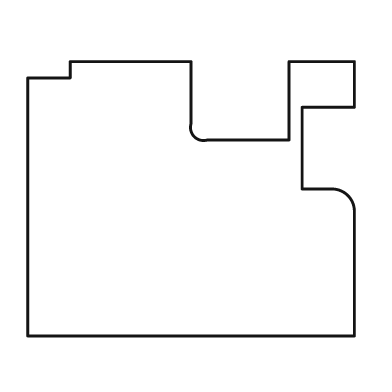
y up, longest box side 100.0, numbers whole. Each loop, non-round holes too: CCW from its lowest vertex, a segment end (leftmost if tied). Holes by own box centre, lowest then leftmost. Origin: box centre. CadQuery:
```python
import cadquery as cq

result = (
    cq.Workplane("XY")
    .moveTo(-50.0, -42.0)
    .lineTo(50.0, -42.0)
    .lineTo(50.0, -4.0)
    .threePointArc((48.0, 1.0), (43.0, 3.0))
    .lineTo(34.0, 3.0)
    .lineTo(34.0, 28.0)
    .lineTo(50.0, 28.0)
    .lineTo(50.0, 42.0)
    .lineTo(30.0, 42.0)
    .lineTo(30.0, 18.0)
    .lineTo(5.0, 18.0)
    .threePointArc((1.0, 19.0), (0.0, 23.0))
    .lineTo(0.0, 42.0)
    .lineTo(-37.0, 42.0)
    .lineTo(-37.0, 37.0)
    .lineTo(-50.0, 37.0)
    .close()
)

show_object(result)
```